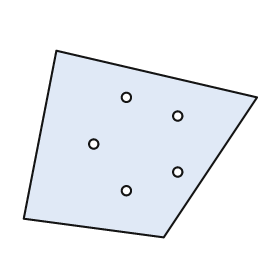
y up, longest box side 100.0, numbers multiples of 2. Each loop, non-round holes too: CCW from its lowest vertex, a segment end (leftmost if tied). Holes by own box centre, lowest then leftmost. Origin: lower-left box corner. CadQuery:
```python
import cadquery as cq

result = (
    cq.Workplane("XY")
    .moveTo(60.0, 0.0)
    .lineTo(100.0, 60.0)
    .lineTo(14.0, 80.0)
    .lineTo(0.0, 8.0)
    .close()
    .moveTo(44.0, 20.0)
    .circle(2.0)
    .moveTo(66.0, 28.0)
    .circle(2.0)
    .moveTo(30.0, 40.0)
    .circle(2.0)
    .moveTo(66.0, 52.0)
    .circle(2.0)
    .moveTo(44.0, 60.0)
    .circle(2.0)
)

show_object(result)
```